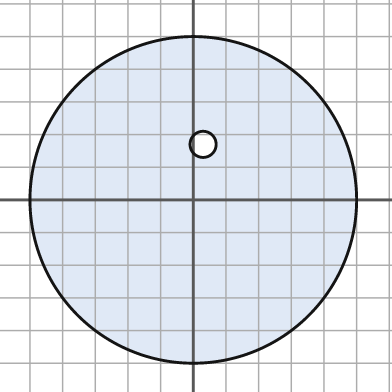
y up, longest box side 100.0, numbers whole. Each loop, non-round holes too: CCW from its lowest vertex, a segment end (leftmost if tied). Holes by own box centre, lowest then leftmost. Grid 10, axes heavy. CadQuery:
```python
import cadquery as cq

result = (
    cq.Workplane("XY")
    .moveTo(0.0, 0.0)
    .circle(50.0)
    .moveTo(3.0, 17.0)
    .circle(4.0)
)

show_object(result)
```